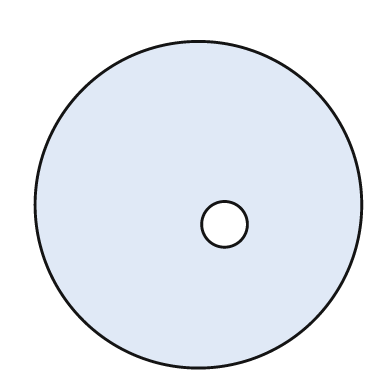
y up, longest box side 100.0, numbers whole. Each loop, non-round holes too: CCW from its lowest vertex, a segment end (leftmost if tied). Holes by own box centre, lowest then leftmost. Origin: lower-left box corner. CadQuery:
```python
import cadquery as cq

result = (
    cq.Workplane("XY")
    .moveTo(50.0, 50.0)
    .circle(50.0)
    .moveTo(58.0, 44.0)
    .circle(7.0)
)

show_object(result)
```